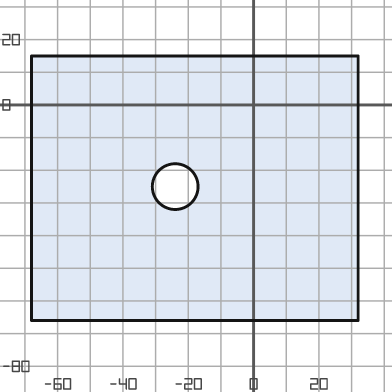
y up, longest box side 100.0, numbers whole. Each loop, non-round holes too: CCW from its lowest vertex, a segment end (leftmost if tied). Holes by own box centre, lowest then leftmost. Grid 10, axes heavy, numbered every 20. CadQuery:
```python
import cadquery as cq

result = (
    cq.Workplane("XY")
    .moveTo(-68.0, -66.0)
    .lineTo(32.0, -66.0)
    .lineTo(32.0, 15.0)
    .lineTo(-68.0, 15.0)
    .close()
    .moveTo(-24.0, -25.0)
    .circle(7.0)
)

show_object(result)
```